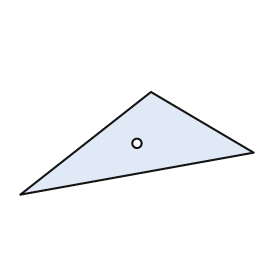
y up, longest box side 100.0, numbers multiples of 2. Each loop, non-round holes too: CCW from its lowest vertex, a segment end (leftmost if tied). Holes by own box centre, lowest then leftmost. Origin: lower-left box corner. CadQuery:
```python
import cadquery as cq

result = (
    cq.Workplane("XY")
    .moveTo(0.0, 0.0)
    .lineTo(100.0, 18.0)
    .lineTo(56.0, 44.0)
    .close()
    .moveTo(50.0, 22.0)
    .circle(2.0)
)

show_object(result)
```